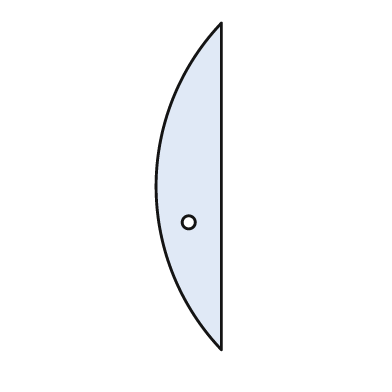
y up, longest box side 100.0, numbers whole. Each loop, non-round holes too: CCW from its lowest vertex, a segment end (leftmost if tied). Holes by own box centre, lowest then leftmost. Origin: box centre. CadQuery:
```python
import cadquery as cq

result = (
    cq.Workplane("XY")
    .moveTo(10.0, -50.0)
    .lineTo(10.0, 50.0)
    .threePointArc((-10.0, 0.0), (10.0, -50.0))
    .close()
    .moveTo(0.0, -11.0)
    .circle(2.0)
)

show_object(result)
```